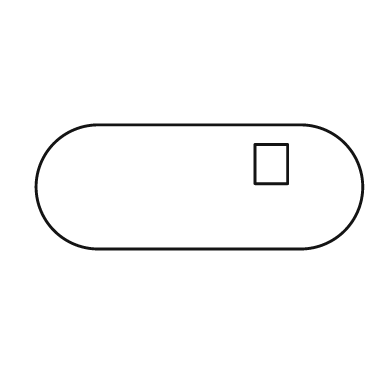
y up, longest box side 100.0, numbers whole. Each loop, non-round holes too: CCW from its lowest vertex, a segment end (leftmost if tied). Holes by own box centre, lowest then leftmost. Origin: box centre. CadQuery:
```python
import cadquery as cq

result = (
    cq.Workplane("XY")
    .moveTo(-31.0, -19.0)
    .lineTo(31.0, -19.0)
    .threePointArc((50.0, 0.0), (31.0, 19.0))
    .lineTo(-31.0, 19.0)
    .threePointArc((-50.0, 0.0), (-31.0, -19.0))
    .close()
    .moveTo(17.0, 1.0)
    .lineTo(27.0, 1.0)
    .lineTo(27.0, 13.0)
    .lineTo(17.0, 13.0)
    .close()
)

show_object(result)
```